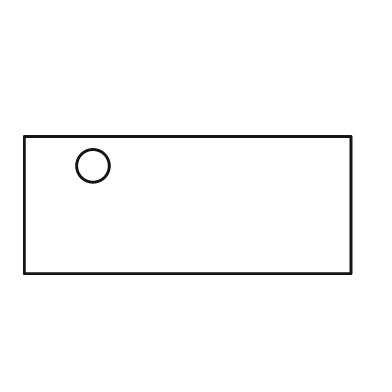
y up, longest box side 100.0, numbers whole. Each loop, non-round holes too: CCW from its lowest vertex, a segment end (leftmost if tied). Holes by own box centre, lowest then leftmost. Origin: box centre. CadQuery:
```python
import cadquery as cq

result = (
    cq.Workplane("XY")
    .moveTo(-50.0, -21.0)
    .lineTo(50.0, -21.0)
    .lineTo(50.0, 21.0)
    .lineTo(-50.0, 21.0)
    .close()
    .moveTo(-29.0, 12.0)
    .circle(5.0)
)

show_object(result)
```